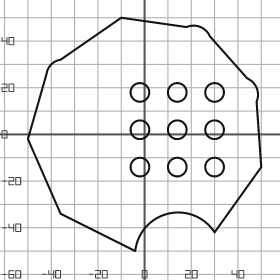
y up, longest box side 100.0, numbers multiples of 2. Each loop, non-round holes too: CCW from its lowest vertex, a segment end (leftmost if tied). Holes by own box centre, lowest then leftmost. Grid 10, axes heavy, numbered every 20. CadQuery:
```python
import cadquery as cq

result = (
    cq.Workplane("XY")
    .moveTo(-4.0, -50.0)
    .threePointArc((10.0, -34.0), (30.0, -42.0))
    .lineTo(50.0, -14.0)
    .lineTo(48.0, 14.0)
    .threePointArc((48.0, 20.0), (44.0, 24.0))
    .lineTo(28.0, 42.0)
    .threePointArc((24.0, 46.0), (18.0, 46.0))
    .lineTo(-10.0, 50.0)
    .lineTo(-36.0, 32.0)
    .threePointArc((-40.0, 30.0), (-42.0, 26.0))
    .lineTo(-50.0, -2.0)
    .lineTo(-36.0, -34.0)
    .close()
    .moveTo(-2.0, -14.0)
    .circle(4.0)
    .moveTo(14.0, -14.0)
    .circle(4.0)
    .moveTo(30.0, -14.0)
    .circle(4.0)
    .moveTo(-2.0, 2.0)
    .circle(4.0)
    .moveTo(14.0, 2.0)
    .circle(4.0)
    .moveTo(30.0, 2.0)
    .circle(4.0)
    .moveTo(-2.0, 18.0)
    .circle(4.0)
    .moveTo(14.0, 18.0)
    .circle(4.0)
    .moveTo(30.0, 18.0)
    .circle(4.0)
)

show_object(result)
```